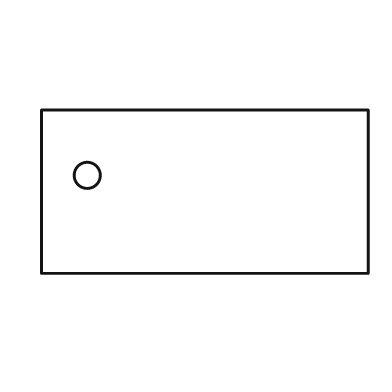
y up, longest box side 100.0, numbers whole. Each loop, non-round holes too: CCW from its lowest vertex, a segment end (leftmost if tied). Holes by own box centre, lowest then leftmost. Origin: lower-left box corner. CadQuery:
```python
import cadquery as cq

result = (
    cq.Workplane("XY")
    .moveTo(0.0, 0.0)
    .lineTo(100.0, 0.0)
    .lineTo(100.0, 50.0)
    .lineTo(0.0, 50.0)
    .close()
    .moveTo(14.0, 30.0)
    .circle(4.0)
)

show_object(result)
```